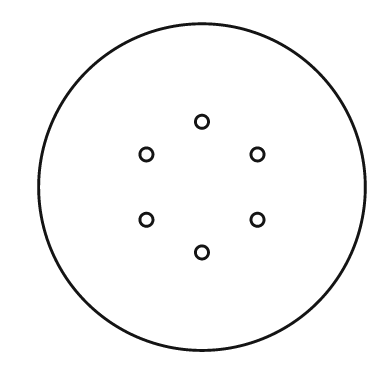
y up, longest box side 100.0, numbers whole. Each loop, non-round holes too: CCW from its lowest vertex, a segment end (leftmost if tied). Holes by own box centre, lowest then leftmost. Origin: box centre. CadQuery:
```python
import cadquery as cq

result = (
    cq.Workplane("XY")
    .moveTo(0.0, 0.0)
    .circle(50.0)
    .moveTo(0.0, -20.0)
    .circle(2.0)
    .moveTo(-17.0, -10.0)
    .circle(2.0)
    .moveTo(17.0, -10.0)
    .circle(2.0)
    .moveTo(-17.0, 10.0)
    .circle(2.0)
    .moveTo(17.0, 10.0)
    .circle(2.0)
    .moveTo(0.0, 20.0)
    .circle(2.0)
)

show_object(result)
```